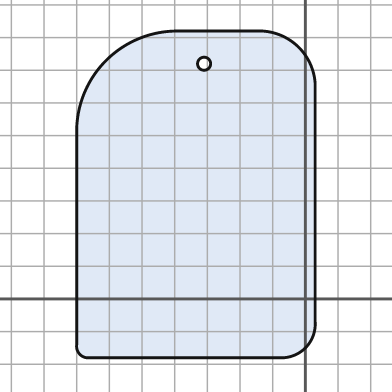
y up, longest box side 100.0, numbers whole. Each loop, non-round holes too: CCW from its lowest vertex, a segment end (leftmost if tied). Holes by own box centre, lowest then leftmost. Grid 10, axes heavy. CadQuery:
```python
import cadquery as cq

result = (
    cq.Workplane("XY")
    .moveTo(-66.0, -18.0)
    .lineTo(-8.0, -18.0)
    .threePointArc((0.0, -15.0), (3.0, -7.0))
    .lineTo(3.0, 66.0)
    .threePointArc((-2.0, 77.0), (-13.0, 82.0))
    .lineTo(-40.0, 82.0)
    .threePointArc((-61.0, 73.0), (-70.0, 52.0))
    .lineTo(-70.0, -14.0)
    .threePointArc((-69.0, -17.0), (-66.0, -18.0))
    .close()
    .moveTo(-31.0, 72.0)
    .circle(2.0)
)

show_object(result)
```